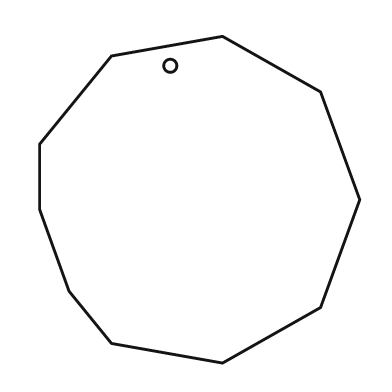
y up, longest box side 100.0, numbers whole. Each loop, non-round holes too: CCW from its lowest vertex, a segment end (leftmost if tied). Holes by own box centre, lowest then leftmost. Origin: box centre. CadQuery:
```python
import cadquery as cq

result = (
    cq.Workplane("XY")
    .moveTo(7.0, -50.0)
    .lineTo(37.0, -33.0)
    .lineTo(49.0, 0.0)
    .lineTo(37.0, 33.0)
    .lineTo(7.0, 50.0)
    .lineTo(-27.0, 44.0)
    .lineTo(-49.0, 17.0)
    .lineTo(-49.0, -3.0)
    .lineTo(-40.0, -28.0)
    .lineTo(-27.0, -44.0)
    .close()
    .moveTo(-9.0, 41.0)
    .circle(2.0)
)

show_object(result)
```